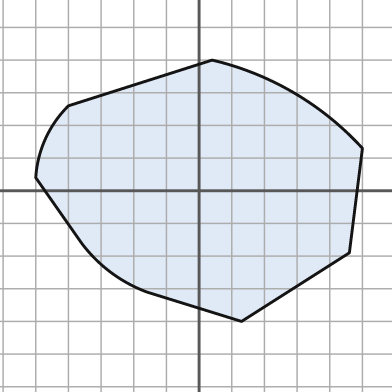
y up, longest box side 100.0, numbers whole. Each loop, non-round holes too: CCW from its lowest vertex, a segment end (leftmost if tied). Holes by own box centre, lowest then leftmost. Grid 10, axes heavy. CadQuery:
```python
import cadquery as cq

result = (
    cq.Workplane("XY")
    .moveTo(13.0, -40.0)
    .lineTo(46.0, -19.0)
    .lineTo(50.0, 13.0)
    .threePointArc((29.0, 30.0), (4.0, 40.0))
    .lineTo(-40.0, 26.0)
    .threePointArc((-47.0, 16.0), (-50.0, 4.0))
    .lineTo(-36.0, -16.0)
    .threePointArc((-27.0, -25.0), (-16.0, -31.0))
    .close()
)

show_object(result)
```